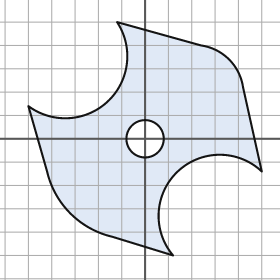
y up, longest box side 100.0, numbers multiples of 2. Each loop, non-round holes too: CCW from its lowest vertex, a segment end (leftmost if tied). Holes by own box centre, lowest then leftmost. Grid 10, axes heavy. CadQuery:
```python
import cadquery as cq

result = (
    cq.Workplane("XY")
    .moveTo(12.0, -50.0)
    .threePointArc((14.0, -14.0), (50.0, -14.0))
    .lineTo(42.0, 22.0)
    .threePointArc((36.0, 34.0), (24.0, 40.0))
    .lineTo(-12.0, 50.0)
    .threePointArc((-16.0, 16.0), (-50.0, 14.0))
    .lineTo(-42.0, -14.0)
    .threePointArc((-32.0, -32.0), (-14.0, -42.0))
    .close()
    .moveTo(0.0, 0.0)
    .circle(8.0)
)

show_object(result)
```